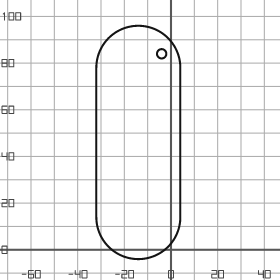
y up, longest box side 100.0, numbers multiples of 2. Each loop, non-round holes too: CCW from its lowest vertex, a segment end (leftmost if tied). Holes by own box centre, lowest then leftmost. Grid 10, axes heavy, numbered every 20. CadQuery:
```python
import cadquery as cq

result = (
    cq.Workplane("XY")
    .moveTo(-32.0, 14.0)
    .threePointArc((-14.0, -4.0), (4.0, 14.0))
    .lineTo(4.0, 78.0)
    .threePointArc((-14.0, 96.0), (-32.0, 78.0))
    .close()
    .moveTo(-4.0, 84.0)
    .circle(2.0)
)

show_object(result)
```